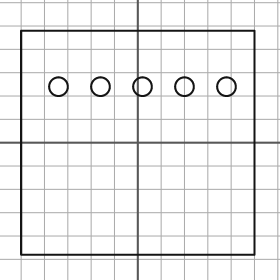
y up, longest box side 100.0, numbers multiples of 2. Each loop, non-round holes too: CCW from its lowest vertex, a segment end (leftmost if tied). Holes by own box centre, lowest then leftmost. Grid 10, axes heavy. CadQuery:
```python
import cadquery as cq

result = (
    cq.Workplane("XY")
    .moveTo(-50.0, -48.0)
    .lineTo(50.0, -48.0)
    .lineTo(50.0, 48.0)
    .lineTo(-50.0, 48.0)
    .close()
    .moveTo(-34.0, 24.0)
    .circle(4.0)
    .moveTo(-16.0, 24.0)
    .circle(4.0)
    .moveTo(2.0, 24.0)
    .circle(4.0)
    .moveTo(20.0, 24.0)
    .circle(4.0)
    .moveTo(38.0, 24.0)
    .circle(4.0)
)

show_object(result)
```